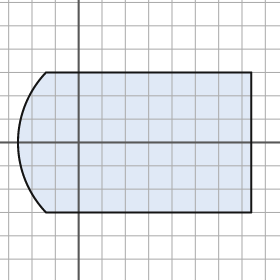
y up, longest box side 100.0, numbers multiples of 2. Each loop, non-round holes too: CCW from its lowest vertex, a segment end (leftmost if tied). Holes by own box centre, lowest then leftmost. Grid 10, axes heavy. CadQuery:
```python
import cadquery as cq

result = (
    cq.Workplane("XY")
    .moveTo(-14.0, -30.0)
    .lineTo(74.0, -30.0)
    .lineTo(74.0, 30.0)
    .lineTo(-14.0, 30.0)
    .threePointArc((-26.0, 0.0), (-14.0, -30.0))
    .close()
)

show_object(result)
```